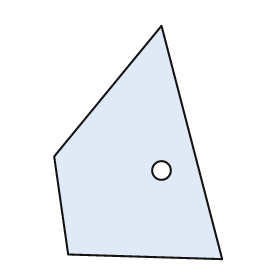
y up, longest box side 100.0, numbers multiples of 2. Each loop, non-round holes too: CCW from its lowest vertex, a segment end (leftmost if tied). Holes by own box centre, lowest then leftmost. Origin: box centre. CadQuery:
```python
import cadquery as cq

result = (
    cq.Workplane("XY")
    .moveTo(36.0, -50.0)
    .lineTo(10.0, 50.0)
    .lineTo(-36.0, -6.0)
    .lineTo(-30.0, -48.0)
    .close()
    .moveTo(10.0, -12.0)
    .circle(4.0)
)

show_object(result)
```